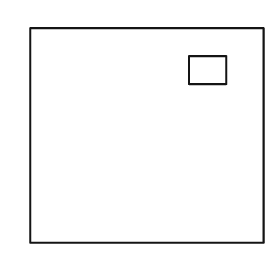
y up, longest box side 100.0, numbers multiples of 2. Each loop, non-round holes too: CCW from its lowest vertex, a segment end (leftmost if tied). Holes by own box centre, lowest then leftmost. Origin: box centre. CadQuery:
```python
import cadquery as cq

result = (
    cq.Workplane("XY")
    .moveTo(-50.0, -46.0)
    .lineTo(50.0, -46.0)
    .lineTo(50.0, 46.0)
    .lineTo(-50.0, 46.0)
    .close()
    .moveTo(18.0, 22.0)
    .lineTo(34.0, 22.0)
    .lineTo(34.0, 34.0)
    .lineTo(18.0, 34.0)
    .close()
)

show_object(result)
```